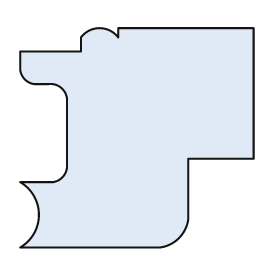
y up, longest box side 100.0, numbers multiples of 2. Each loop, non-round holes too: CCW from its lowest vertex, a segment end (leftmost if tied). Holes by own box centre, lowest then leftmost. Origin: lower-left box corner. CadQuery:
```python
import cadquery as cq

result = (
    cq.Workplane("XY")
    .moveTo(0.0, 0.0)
    .lineTo(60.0, 0.0)
    .threePointArc((68.0, 4.0), (72.0, 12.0))
    .lineTo(72.0, 38.0)
    .lineTo(100.0, 38.0)
    .lineTo(100.0, 94.0)
    .lineTo(42.0, 94.0)
    .lineTo(42.0, 90.0)
    .threePointArc((34.0, 94.0), (26.0, 90.0))
    .lineTo(26.0, 84.0)
    .lineTo(0.0, 84.0)
    .lineTo(0.0, 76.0)
    .threePointArc((2.0, 72.0), (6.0, 70.0))
    .lineTo(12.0, 70.0)
    .threePointArc((18.0, 68.0), (20.0, 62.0))
    .lineTo(20.0, 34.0)
    .threePointArc((18.0, 30.0), (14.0, 28.0))
    .lineTo(0.0, 28.0)
    .threePointArc((8.0, 14.0), (0.0, 0.0))
    .close()
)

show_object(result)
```